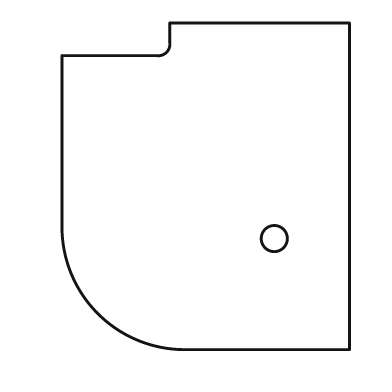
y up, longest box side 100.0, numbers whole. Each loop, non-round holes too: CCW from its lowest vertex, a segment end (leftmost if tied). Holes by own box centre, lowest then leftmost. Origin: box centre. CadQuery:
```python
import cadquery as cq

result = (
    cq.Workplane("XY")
    .moveTo(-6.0, -50.0)
    .lineTo(44.0, -50.0)
    .lineTo(44.0, 50.0)
    .lineTo(-11.0, 50.0)
    .lineTo(-11.0, 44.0)
    .threePointArc((-12.0, 41.0), (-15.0, 40.0))
    .lineTo(-44.0, 40.0)
    .lineTo(-44.0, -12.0)
    .threePointArc((-33.0, -39.0), (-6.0, -50.0))
    .close()
    .moveTo(21.0, -16.0)
    .circle(4.0)
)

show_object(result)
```